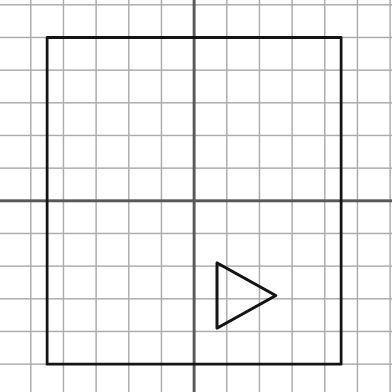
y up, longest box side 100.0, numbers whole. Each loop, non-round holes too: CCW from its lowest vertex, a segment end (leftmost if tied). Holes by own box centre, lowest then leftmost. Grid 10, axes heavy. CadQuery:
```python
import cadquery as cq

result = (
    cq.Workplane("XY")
    .moveTo(-45.0, -50.0)
    .lineTo(45.0, -50.0)
    .lineTo(45.0, 50.0)
    .lineTo(-45.0, 50.0)
    .close()
    .moveTo(7.0, -39.0)
    .lineTo(25.0, -29.0)
    .lineTo(7.0, -19.0)
    .close()
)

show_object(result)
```